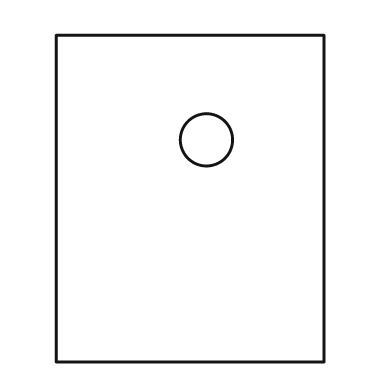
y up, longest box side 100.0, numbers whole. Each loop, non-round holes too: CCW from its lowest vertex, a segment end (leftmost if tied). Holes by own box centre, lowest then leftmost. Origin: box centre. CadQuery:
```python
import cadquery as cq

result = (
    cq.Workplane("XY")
    .moveTo(-41.0, -50.0)
    .lineTo(41.0, -50.0)
    .lineTo(41.0, 50.0)
    .lineTo(-41.0, 50.0)
    .close()
    .moveTo(5.0, 18.0)
    .circle(8.0)
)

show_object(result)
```